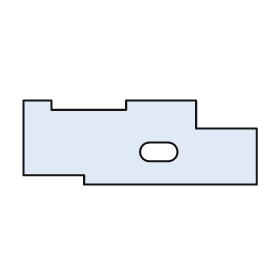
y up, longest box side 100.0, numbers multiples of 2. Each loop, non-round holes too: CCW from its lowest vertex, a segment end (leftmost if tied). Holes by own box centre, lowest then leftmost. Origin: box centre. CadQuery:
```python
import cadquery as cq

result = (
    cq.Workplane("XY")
    .moveTo(-24.0, -18.0)
    .lineTo(50.0, -18.0)
    .lineTo(50.0, 6.0)
    .lineTo(24.0, 6.0)
    .lineTo(24.0, 18.0)
    .lineTo(-6.0, 18.0)
    .lineTo(-6.0, 14.0)
    .lineTo(-38.0, 14.0)
    .lineTo(-38.0, 18.0)
    .lineTo(-50.0, 18.0)
    .lineTo(-50.0, -14.0)
    .lineTo(-24.0, -14.0)
    .close()
    .moveTo(4.0, -8.0)
    .lineTo(12.0, -8.0)
    .threePointArc((16.0, -4.0), (12.0, 0.0))
    .lineTo(4.0, 0.0)
    .threePointArc((0.0, -4.0), (4.0, -8.0))
    .close()
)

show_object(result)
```